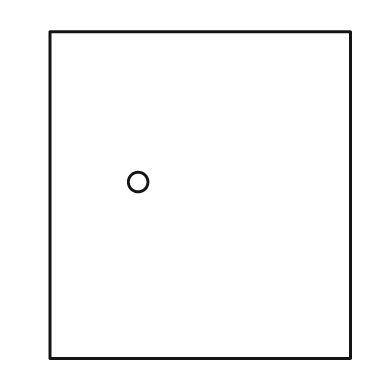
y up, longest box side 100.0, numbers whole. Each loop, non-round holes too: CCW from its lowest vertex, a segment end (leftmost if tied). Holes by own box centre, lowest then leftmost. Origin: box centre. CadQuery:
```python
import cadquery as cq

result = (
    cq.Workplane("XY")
    .moveTo(-46.0, -50.0)
    .lineTo(46.0, -50.0)
    .lineTo(46.0, 50.0)
    .lineTo(-46.0, 50.0)
    .close()
    .moveTo(-19.0, 4.0)
    .circle(3.0)
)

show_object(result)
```